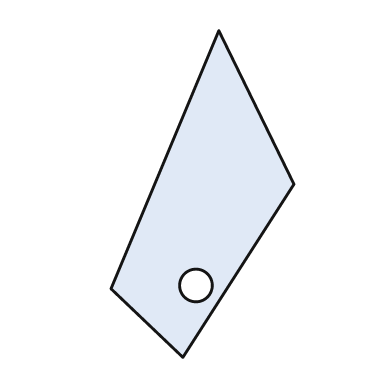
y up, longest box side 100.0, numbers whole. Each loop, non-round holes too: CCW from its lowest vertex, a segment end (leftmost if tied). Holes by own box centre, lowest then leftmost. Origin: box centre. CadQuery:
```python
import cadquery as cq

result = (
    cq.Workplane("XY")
    .moveTo(-6.0, -50.0)
    .lineTo(28.0, 3.0)
    .lineTo(5.0, 50.0)
    .lineTo(-28.0, -29.0)
    .close()
    .moveTo(-2.0, -28.0)
    .circle(5.0)
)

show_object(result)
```